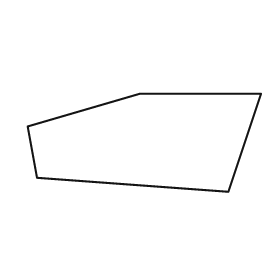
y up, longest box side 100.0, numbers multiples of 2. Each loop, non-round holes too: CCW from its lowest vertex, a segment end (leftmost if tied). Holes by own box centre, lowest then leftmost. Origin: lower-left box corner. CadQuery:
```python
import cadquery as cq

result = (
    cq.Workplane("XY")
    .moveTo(86.0, 0.0)
    .lineTo(100.0, 42.0)
    .lineTo(48.0, 42.0)
    .lineTo(0.0, 28.0)
    .lineTo(4.0, 6.0)
    .close()
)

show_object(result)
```